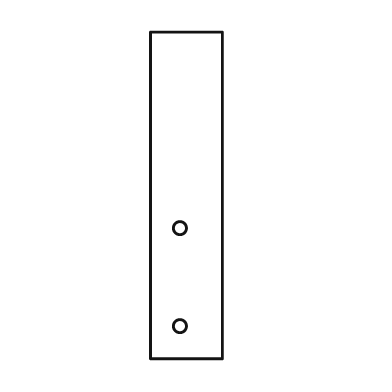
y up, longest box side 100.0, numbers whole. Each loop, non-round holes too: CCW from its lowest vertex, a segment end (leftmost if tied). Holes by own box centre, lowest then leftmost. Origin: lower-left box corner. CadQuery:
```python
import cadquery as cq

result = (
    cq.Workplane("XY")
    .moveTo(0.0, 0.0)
    .lineTo(22.0, 0.0)
    .lineTo(22.0, 100.0)
    .lineTo(0.0, 100.0)
    .close()
    .moveTo(9.0, 10.0)
    .circle(2.0)
    .moveTo(9.0, 40.0)
    .circle(2.0)
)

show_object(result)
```